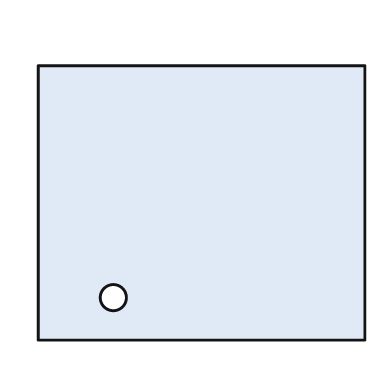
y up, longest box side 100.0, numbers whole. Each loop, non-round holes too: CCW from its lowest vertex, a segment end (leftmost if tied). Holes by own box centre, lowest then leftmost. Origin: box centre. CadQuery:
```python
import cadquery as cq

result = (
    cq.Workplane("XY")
    .moveTo(-50.0, -42.0)
    .lineTo(50.0, -42.0)
    .lineTo(50.0, 42.0)
    .lineTo(-50.0, 42.0)
    .close()
    .moveTo(-27.0, -29.0)
    .circle(4.0)
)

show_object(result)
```